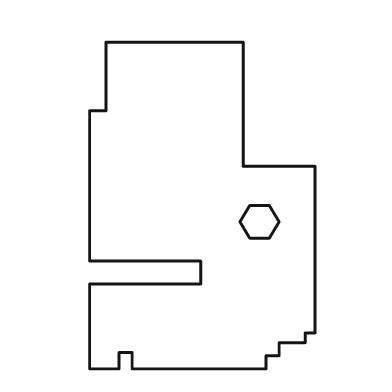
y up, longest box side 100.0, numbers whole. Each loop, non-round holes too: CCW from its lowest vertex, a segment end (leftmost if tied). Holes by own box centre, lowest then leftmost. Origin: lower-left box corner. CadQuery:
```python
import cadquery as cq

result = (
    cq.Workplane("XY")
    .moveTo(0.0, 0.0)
    .lineTo(9.0, 0.0)
    .lineTo(9.0, 5.0)
    .lineTo(13.0, 5.0)
    .lineTo(13.0, 0.0)
    .lineTo(54.0, 0.0)
    .lineTo(54.0, 4.0)
    .lineTo(58.0, 4.0)
    .lineTo(58.0, 8.0)
    .lineTo(66.0, 8.0)
    .lineTo(66.0, 11.0)
    .lineTo(69.0, 11.0)
    .lineTo(69.0, 62.0)
    .lineTo(47.0, 62.0)
    .lineTo(47.0, 100.0)
    .lineTo(5.0, 100.0)
    .lineTo(5.0, 79.0)
    .lineTo(0.0, 79.0)
    .lineTo(0.0, 33.0)
    .lineTo(34.0, 33.0)
    .lineTo(34.0, 26.0)
    .lineTo(0.0, 26.0)
    .close()
    .moveTo(49.0, 40.0)
    .lineTo(55.0, 40.0)
    .lineTo(58.0, 45.0)
    .lineTo(55.0, 50.0)
    .lineTo(49.0, 50.0)
    .lineTo(46.0, 45.0)
    .close()
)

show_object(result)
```